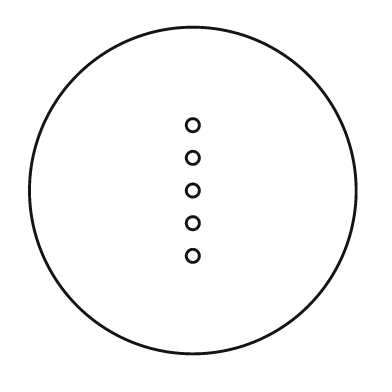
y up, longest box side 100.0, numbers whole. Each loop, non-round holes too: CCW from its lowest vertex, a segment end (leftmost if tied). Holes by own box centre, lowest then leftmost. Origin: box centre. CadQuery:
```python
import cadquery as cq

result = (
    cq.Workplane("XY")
    .moveTo(0.0, 0.0)
    .circle(50.0)
    .moveTo(0.0, -20.0)
    .circle(2.0)
    .moveTo(0.0, -10.0)
    .circle(2.0)
    .moveTo(0.0, 0.0)
    .circle(2.0)
    .moveTo(0.0, 10.0)
    .circle(2.0)
    .moveTo(0.0, 20.0)
    .circle(2.0)
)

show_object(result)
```